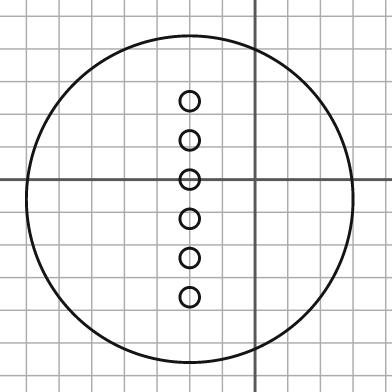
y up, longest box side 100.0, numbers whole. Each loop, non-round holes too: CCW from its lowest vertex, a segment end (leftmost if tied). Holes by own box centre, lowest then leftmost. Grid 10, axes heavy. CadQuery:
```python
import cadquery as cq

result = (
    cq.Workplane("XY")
    .moveTo(-20.0, -6.0)
    .circle(50.0)
    .moveTo(-20.0, -36.0)
    .circle(3.0)
    .moveTo(-20.0, -24.0)
    .circle(3.0)
    .moveTo(-20.0, -12.0)
    .circle(3.0)
    .moveTo(-20.0, 0.0)
    .circle(3.0)
    .moveTo(-20.0, 12.0)
    .circle(3.0)
    .moveTo(-20.0, 24.0)
    .circle(3.0)
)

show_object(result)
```